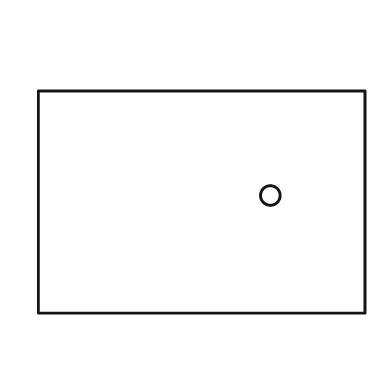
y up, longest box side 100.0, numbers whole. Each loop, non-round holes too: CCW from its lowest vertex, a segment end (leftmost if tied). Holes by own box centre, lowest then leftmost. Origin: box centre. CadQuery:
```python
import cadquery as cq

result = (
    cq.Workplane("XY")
    .moveTo(-50.0, -34.0)
    .lineTo(50.0, -34.0)
    .lineTo(50.0, 34.0)
    .lineTo(-50.0, 34.0)
    .close()
    .moveTo(21.0, 2.0)
    .circle(3.0)
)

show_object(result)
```